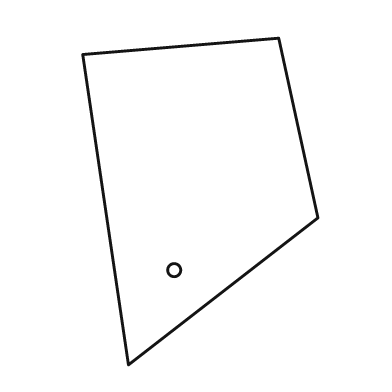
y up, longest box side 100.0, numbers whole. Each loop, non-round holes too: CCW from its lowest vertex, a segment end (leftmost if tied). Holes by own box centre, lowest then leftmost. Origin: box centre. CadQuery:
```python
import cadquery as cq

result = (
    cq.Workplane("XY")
    .moveTo(-22.0, -50.0)
    .lineTo(36.0, -5.0)
    .lineTo(24.0, 50.0)
    .lineTo(-36.0, 45.0)
    .close()
    .moveTo(-8.0, -21.0)
    .circle(2.0)
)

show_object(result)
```